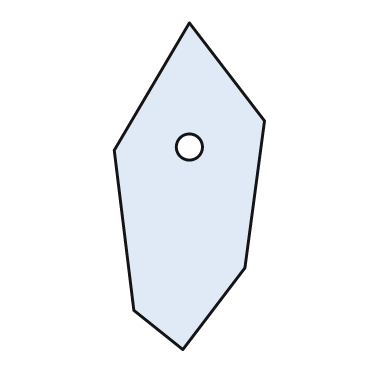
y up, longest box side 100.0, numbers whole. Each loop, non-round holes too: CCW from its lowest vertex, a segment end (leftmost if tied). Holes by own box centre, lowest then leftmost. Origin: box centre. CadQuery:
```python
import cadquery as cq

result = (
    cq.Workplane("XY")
    .moveTo(-2.0, -50.0)
    .lineTo(17.0, -25.0)
    .lineTo(23.0, 20.0)
    .lineTo(0.0, 50.0)
    .lineTo(-23.0, 11.0)
    .lineTo(-17.0, -38.0)
    .close()
    .moveTo(0.0, 12.0)
    .circle(4.0)
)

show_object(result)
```